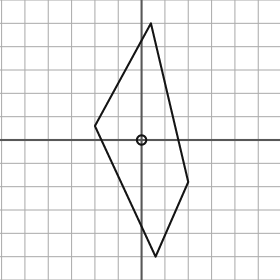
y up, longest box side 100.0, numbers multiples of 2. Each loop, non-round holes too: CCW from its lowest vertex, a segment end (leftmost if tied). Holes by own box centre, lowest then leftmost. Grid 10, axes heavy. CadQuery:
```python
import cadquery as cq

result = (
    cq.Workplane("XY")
    .moveTo(6.0, -50.0)
    .lineTo(20.0, -18.0)
    .lineTo(4.0, 50.0)
    .lineTo(-20.0, 6.0)
    .close()
    .moveTo(0.0, 0.0)
    .circle(2.0)
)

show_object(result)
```